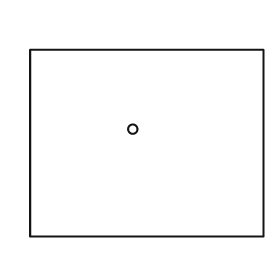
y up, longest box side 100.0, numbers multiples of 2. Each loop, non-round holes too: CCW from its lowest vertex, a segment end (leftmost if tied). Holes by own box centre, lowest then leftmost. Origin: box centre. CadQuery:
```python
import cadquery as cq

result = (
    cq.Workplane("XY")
    .moveTo(-50.0, -40.0)
    .lineTo(50.0, -40.0)
    .lineTo(50.0, 40.0)
    .lineTo(-50.0, 40.0)
    .close()
    .moveTo(-6.0, 6.0)
    .circle(2.0)
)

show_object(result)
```